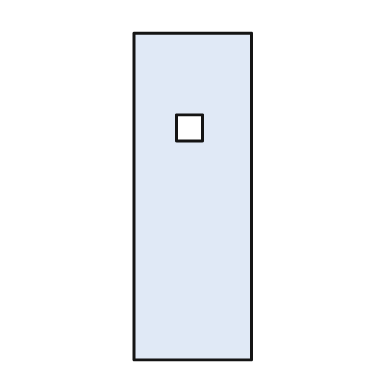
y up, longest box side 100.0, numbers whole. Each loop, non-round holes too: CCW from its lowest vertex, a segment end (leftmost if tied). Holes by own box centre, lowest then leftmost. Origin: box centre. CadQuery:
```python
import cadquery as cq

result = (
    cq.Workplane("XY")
    .moveTo(-18.0, -50.0)
    .lineTo(18.0, -50.0)
    .lineTo(18.0, 50.0)
    .lineTo(-18.0, 50.0)
    .close()
    .moveTo(-5.0, 17.0)
    .lineTo(3.0, 17.0)
    .lineTo(3.0, 25.0)
    .lineTo(-5.0, 25.0)
    .close()
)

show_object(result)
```